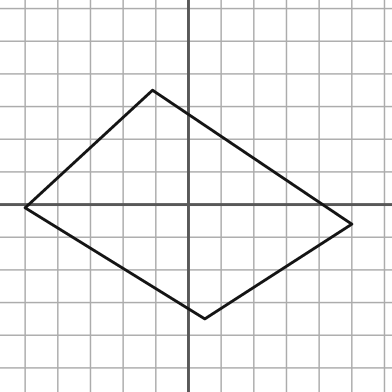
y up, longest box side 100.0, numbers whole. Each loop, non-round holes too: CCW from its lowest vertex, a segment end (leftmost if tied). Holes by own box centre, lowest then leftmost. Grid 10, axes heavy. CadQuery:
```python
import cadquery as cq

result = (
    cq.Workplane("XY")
    .moveTo(5.0, -35.0)
    .lineTo(50.0, -6.0)
    .lineTo(-11.0, 35.0)
    .lineTo(-50.0, -1.0)
    .close()
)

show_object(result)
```